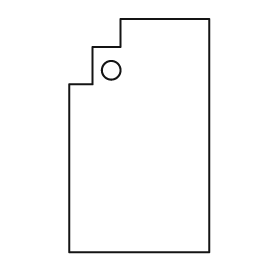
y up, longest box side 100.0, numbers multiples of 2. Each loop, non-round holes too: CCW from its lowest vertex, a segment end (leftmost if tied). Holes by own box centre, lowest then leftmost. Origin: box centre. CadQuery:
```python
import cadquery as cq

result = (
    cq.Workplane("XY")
    .moveTo(-30.0, -50.0)
    .lineTo(30.0, -50.0)
    .lineTo(30.0, 50.0)
    .lineTo(-8.0, 50.0)
    .lineTo(-8.0, 38.0)
    .lineTo(-20.0, 38.0)
    .lineTo(-20.0, 22.0)
    .lineTo(-30.0, 22.0)
    .close()
    .moveTo(-12.0, 28.0)
    .circle(4.0)
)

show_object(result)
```